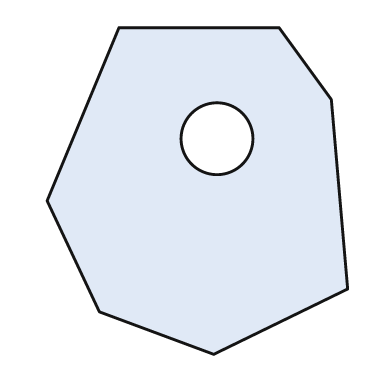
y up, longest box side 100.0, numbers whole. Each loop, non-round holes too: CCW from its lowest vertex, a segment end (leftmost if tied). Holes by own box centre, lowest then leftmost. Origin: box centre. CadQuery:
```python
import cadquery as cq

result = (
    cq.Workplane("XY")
    .moveTo(5.0, -50.0)
    .lineTo(46.0, -30.0)
    .lineTo(41.0, 28.0)
    .lineTo(25.0, 50.0)
    .lineTo(-24.0, 50.0)
    .lineTo(-46.0, -3.0)
    .lineTo(-30.0, -37.0)
    .close()
    .moveTo(6.0, 16.0)
    .circle(11.0)
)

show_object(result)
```